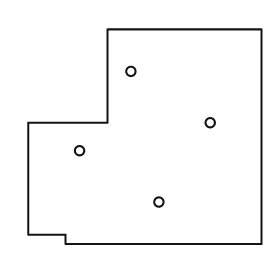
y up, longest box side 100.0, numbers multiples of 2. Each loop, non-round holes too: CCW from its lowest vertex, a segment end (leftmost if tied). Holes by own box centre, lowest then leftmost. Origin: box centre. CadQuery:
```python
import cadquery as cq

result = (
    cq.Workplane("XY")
    .moveTo(-34.0, -46.0)
    .lineTo(50.0, -46.0)
    .lineTo(50.0, 46.0)
    .lineTo(-16.0, 46.0)
    .lineTo(-16.0, 6.0)
    .lineTo(-50.0, 6.0)
    .lineTo(-50.0, -42.0)
    .lineTo(-34.0, -42.0)
    .close()
    .moveTo(6.0, -28.0)
    .circle(2.0)
    .moveTo(-28.0, -6.0)
    .circle(2.0)
    .moveTo(28.0, 6.0)
    .circle(2.0)
    .moveTo(-6.0, 28.0)
    .circle(2.0)
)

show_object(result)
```